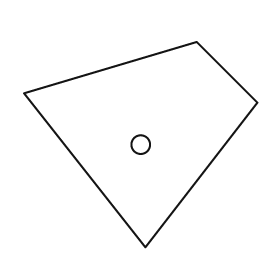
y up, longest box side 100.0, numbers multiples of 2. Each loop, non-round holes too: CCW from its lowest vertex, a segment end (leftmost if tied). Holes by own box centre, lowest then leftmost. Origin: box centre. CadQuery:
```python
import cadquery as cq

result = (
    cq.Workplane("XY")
    .moveTo(2.0, -44.0)
    .lineTo(50.0, 18.0)
    .lineTo(24.0, 44.0)
    .lineTo(-50.0, 22.0)
    .close()
    .moveTo(0.0, 0.0)
    .circle(4.0)
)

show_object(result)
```